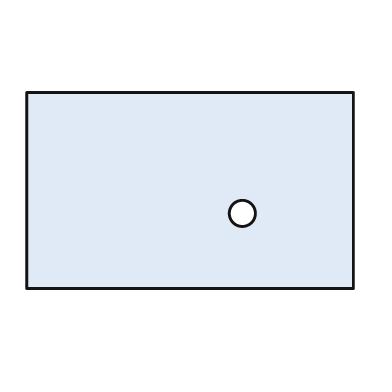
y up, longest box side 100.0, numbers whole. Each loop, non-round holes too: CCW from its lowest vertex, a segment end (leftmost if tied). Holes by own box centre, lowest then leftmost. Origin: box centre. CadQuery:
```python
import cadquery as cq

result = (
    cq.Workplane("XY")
    .moveTo(-50.0, -30.0)
    .lineTo(50.0, -30.0)
    .lineTo(50.0, 30.0)
    .lineTo(-50.0, 30.0)
    .close()
    .moveTo(16.0, -7.0)
    .circle(4.0)
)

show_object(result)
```